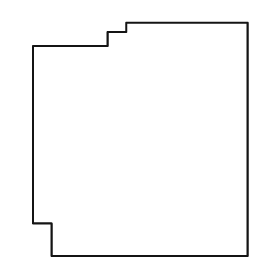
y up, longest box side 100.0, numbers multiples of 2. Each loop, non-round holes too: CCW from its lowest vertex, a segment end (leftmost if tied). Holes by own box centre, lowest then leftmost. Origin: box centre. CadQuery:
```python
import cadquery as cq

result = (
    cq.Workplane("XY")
    .moveTo(-38.0, -50.0)
    .lineTo(46.0, -50.0)
    .lineTo(46.0, 50.0)
    .lineTo(-6.0, 50.0)
    .lineTo(-6.0, 46.0)
    .lineTo(-14.0, 46.0)
    .lineTo(-14.0, 40.0)
    .lineTo(-46.0, 40.0)
    .lineTo(-46.0, -36.0)
    .lineTo(-38.0, -36.0)
    .close()
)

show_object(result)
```